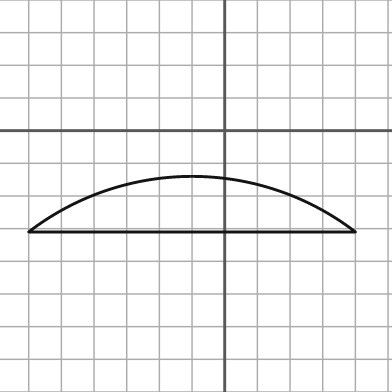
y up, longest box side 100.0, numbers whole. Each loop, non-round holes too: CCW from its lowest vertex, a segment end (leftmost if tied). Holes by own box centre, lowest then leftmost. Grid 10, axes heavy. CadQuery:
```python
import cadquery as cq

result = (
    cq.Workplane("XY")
    .moveTo(-60.0, -31.0)
    .lineTo(40.0, -31.0)
    .threePointArc((-10.0, -14.0), (-60.0, -31.0))
    .close()
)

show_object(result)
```